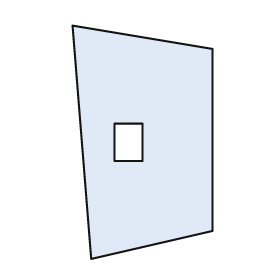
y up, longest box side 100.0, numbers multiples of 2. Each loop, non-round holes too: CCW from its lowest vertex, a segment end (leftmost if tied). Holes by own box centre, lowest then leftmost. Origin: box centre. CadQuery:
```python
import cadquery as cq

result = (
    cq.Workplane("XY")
    .moveTo(-22.0, -50.0)
    .lineTo(30.0, -38.0)
    .lineTo(30.0, 40.0)
    .lineTo(-30.0, 50.0)
    .close()
    .moveTo(-12.0, -8.0)
    .lineTo(0.0, -8.0)
    .lineTo(0.0, 8.0)
    .lineTo(-12.0, 8.0)
    .close()
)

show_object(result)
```